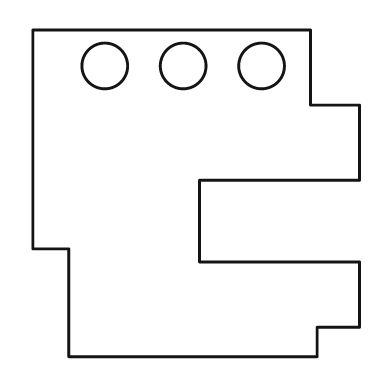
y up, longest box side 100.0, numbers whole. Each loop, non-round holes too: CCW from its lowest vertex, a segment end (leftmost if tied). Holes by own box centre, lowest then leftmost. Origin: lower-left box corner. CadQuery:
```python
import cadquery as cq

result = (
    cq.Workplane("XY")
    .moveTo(11.0, 0.0)
    .lineTo(87.0, 0.0)
    .lineTo(87.0, 9.0)
    .lineTo(100.0, 9.0)
    .lineTo(100.0, 29.0)
    .lineTo(51.0, 29.0)
    .lineTo(51.0, 54.0)
    .lineTo(100.0, 54.0)
    .lineTo(100.0, 77.0)
    .lineTo(85.0, 77.0)
    .lineTo(85.0, 100.0)
    .lineTo(0.0, 100.0)
    .lineTo(0.0, 33.0)
    .lineTo(11.0, 33.0)
    .close()
    .moveTo(22.0, 89.0)
    .circle(7.0)
    .moveTo(46.0, 89.0)
    .circle(7.0)
    .moveTo(70.0, 89.0)
    .circle(7.0)
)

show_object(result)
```